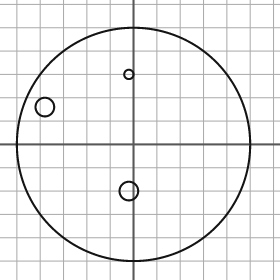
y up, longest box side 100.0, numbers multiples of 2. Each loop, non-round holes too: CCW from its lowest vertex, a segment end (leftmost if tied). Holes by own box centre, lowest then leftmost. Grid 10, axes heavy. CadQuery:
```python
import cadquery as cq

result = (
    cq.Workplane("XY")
    .moveTo(0.0, 0.0)
    .circle(50.0)
    .moveTo(-2.0, -20.0)
    .circle(4.0)
    .moveTo(-38.0, 16.0)
    .circle(4.0)
    .moveTo(-2.0, 30.0)
    .circle(2.0)
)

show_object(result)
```